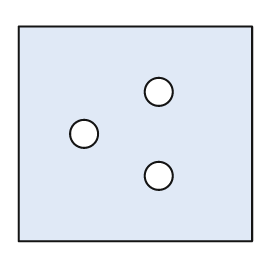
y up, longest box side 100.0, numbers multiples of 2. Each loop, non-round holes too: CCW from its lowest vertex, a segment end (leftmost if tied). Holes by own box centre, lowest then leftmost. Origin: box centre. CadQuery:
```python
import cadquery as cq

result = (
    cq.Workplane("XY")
    .moveTo(-50.0, -46.0)
    .lineTo(50.0, -46.0)
    .lineTo(50.0, 46.0)
    .lineTo(-50.0, 46.0)
    .close()
    .moveTo(10.0, -18.0)
    .circle(6.0)
    .moveTo(-22.0, 0.0)
    .circle(6.0)
    .moveTo(10.0, 18.0)
    .circle(6.0)
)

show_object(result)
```